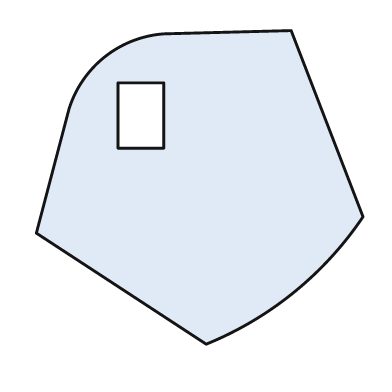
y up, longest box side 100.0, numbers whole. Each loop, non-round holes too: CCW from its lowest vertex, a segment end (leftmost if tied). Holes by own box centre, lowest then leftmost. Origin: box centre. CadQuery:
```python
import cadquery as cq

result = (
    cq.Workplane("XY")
    .moveTo(2.0, -48.0)
    .threePointArc((29.0, -32.0), (50.0, -9.0))
    .lineTo(28.0, 48.0)
    .lineTo(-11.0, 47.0)
    .threePointArc((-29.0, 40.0), (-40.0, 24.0))
    .lineTo(-50.0, -14.0)
    .close()
    .moveTo(-25.0, 12.0)
    .lineTo(-11.0, 12.0)
    .lineTo(-11.0, 32.0)
    .lineTo(-25.0, 32.0)
    .close()
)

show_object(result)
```